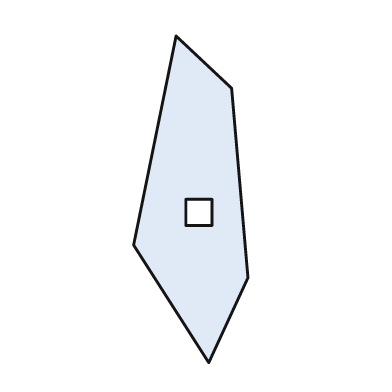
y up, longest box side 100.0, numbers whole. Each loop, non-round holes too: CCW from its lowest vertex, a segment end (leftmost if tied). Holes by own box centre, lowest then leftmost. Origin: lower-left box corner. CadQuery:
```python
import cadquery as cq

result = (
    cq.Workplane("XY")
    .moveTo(23.0, 0.0)
    .lineTo(35.0, 26.0)
    .lineTo(30.0, 84.0)
    .lineTo(13.0, 100.0)
    .lineTo(0.0, 36.0)
    .close()
    .moveTo(16.0, 42.0)
    .lineTo(24.0, 42.0)
    .lineTo(24.0, 50.0)
    .lineTo(16.0, 50.0)
    .close()
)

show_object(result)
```